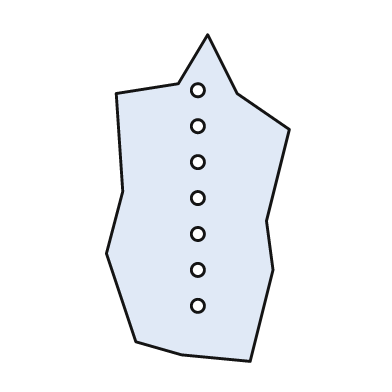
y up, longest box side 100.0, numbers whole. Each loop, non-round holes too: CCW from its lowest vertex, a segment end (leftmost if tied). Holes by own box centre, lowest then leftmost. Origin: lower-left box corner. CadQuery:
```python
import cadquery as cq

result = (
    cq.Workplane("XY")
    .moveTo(44.0, 0.0)
    .lineTo(51.0, 28.0)
    .lineTo(49.0, 43.0)
    .lineTo(56.0, 71.0)
    .lineTo(40.0, 82.0)
    .lineTo(31.0, 100.0)
    .lineTo(22.0, 85.0)
    .lineTo(3.0, 82.0)
    .lineTo(5.0, 52.0)
    .lineTo(0.0, 33.0)
    .lineTo(9.0, 6.0)
    .lineTo(23.0, 2.0)
    .close()
    .moveTo(28.0, 17.0)
    .circle(2.0)
    .moveTo(28.0, 28.0)
    .circle(2.0)
    .moveTo(28.0, 39.0)
    .circle(2.0)
    .moveTo(28.0, 50.0)
    .circle(2.0)
    .moveTo(28.0, 61.0)
    .circle(2.0)
    .moveTo(28.0, 72.0)
    .circle(2.0)
    .moveTo(28.0, 83.0)
    .circle(2.0)
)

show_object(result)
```